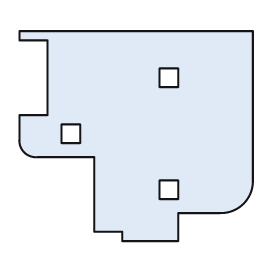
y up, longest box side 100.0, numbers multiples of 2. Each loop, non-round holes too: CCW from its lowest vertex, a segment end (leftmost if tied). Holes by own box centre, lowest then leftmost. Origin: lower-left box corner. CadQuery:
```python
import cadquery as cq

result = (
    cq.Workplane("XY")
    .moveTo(44.0, 0.0)
    .lineTo(68.0, 0.0)
    .lineTo(68.0, 12.0)
    .lineTo(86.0, 12.0)
    .threePointArc((96.0, 16.0), (100.0, 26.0))
    .lineTo(100.0, 90.0)
    .lineTo(0.0, 90.0)
    .lineTo(0.0, 86.0)
    .lineTo(12.0, 86.0)
    .lineTo(12.0, 54.0)
    .lineTo(0.0, 54.0)
    .lineTo(0.0, 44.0)
    .threePointArc((2.0, 38.0), (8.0, 36.0))
    .lineTo(32.0, 36.0)
    .lineTo(32.0, 4.0)
    .lineTo(44.0, 4.0)
    .close()
    .moveTo(60.0, 18.0)
    .lineTo(68.0, 18.0)
    .lineTo(68.0, 26.0)
    .lineTo(60.0, 26.0)
    .close()
    .moveTo(18.0, 42.0)
    .lineTo(26.0, 42.0)
    .lineTo(26.0, 50.0)
    .lineTo(18.0, 50.0)
    .close()
    .moveTo(60.0, 66.0)
    .lineTo(68.0, 66.0)
    .lineTo(68.0, 74.0)
    .lineTo(60.0, 74.0)
    .close()
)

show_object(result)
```